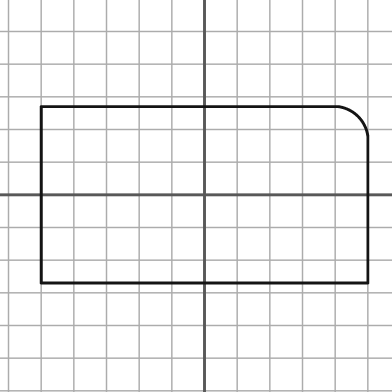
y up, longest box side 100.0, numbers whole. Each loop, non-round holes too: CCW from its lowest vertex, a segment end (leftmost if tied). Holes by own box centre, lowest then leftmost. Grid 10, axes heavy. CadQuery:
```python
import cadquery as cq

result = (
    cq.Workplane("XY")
    .moveTo(-50.0, -27.0)
    .lineTo(50.0, -27.0)
    .lineTo(50.0, 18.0)
    .threePointArc((47.0, 24.0), (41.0, 27.0))
    .lineTo(-50.0, 27.0)
    .close()
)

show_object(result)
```